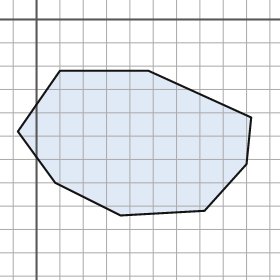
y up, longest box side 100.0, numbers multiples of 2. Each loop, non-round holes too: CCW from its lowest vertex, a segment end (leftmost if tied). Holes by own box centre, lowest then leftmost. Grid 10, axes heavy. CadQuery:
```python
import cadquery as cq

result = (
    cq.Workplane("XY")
    .moveTo(36.0, -84.0)
    .lineTo(72.0, -82.0)
    .lineTo(90.0, -62.0)
    .lineTo(92.0, -42.0)
    .lineTo(48.0, -22.0)
    .lineTo(10.0, -22.0)
    .lineTo(-8.0, -48.0)
    .lineTo(8.0, -70.0)
    .close()
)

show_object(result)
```